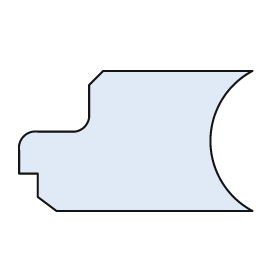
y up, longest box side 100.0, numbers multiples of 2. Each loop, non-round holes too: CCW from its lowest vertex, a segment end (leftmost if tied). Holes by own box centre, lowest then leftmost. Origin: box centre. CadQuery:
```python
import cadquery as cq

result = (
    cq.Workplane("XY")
    .moveTo(-34.0, -30.0)
    .lineTo(50.0, -30.0)
    .threePointArc((32.0, 0.0), (50.0, 30.0))
    .lineTo(-14.0, 30.0)
    .lineTo(-20.0, 24.0)
    .lineTo(-20.0, 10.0)
    .threePointArc((-22.0, 6.0), (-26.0, 4.0))
    .lineTo(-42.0, 4.0)
    .threePointArc((-48.0, 2.0), (-50.0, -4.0))
    .lineTo(-50.0, -14.0)
    .lineTo(-42.0, -14.0)
    .lineTo(-42.0, -24.0)
    .close()
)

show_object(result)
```